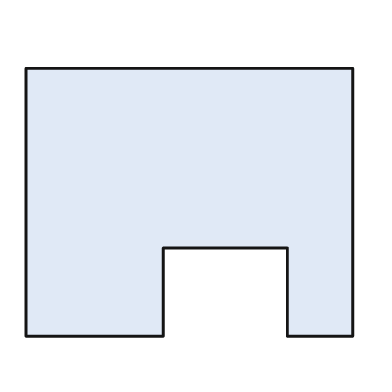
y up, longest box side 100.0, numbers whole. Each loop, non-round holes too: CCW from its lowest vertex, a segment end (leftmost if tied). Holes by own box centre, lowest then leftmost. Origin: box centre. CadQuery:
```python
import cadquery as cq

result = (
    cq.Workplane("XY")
    .moveTo(-50.0, -41.0)
    .lineTo(-8.0, -41.0)
    .lineTo(-8.0, -14.0)
    .lineTo(30.0, -14.0)
    .lineTo(30.0, -41.0)
    .lineTo(50.0, -41.0)
    .lineTo(50.0, 41.0)
    .lineTo(-50.0, 41.0)
    .close()
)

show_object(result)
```